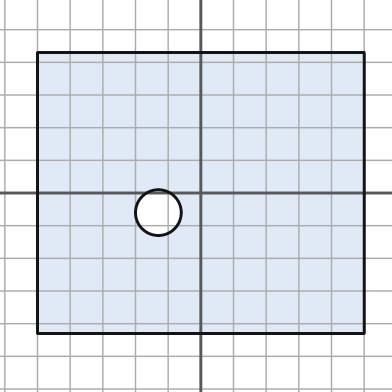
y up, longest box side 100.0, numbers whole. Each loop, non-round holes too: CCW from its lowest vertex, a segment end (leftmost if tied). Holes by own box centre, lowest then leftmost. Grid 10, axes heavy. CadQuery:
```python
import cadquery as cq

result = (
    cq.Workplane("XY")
    .moveTo(-50.0, -43.0)
    .lineTo(50.0, -43.0)
    .lineTo(50.0, 43.0)
    .lineTo(-50.0, 43.0)
    .close()
    .moveTo(-13.0, -6.0)
    .circle(7.0)
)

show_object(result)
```